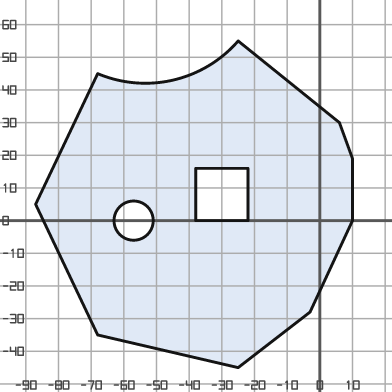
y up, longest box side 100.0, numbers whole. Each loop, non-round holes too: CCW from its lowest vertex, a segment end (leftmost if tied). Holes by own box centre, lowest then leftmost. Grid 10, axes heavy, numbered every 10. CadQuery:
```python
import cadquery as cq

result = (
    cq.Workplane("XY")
    .moveTo(-25.0, -45.0)
    .lineTo(-3.0, -28.0)
    .lineTo(10.0, 0.0)
    .lineTo(10.0, 19.0)
    .lineTo(6.0, 30.0)
    .lineTo(-25.0, 55.0)
    .threePointArc((-45.0, 43.0), (-68.0, 45.0))
    .lineTo(-87.0, 5.0)
    .lineTo(-68.0, -35.0)
    .close()
    .moveTo(-57.0, 0.0)
    .circle(6.0)
    .moveTo(-38.0, 0.0)
    .lineTo(-22.0, 0.0)
    .lineTo(-22.0, 16.0)
    .lineTo(-38.0, 16.0)
    .close()
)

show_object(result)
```